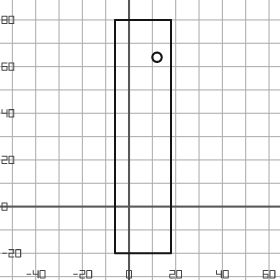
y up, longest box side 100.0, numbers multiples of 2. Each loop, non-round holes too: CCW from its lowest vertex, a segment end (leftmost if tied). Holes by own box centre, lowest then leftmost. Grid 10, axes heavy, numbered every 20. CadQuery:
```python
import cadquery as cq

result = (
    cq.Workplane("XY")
    .moveTo(-6.0, -20.0)
    .lineTo(18.0, -20.0)
    .lineTo(18.0, 80.0)
    .lineTo(-6.0, 80.0)
    .close()
    .moveTo(12.0, 64.0)
    .circle(2.0)
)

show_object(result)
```